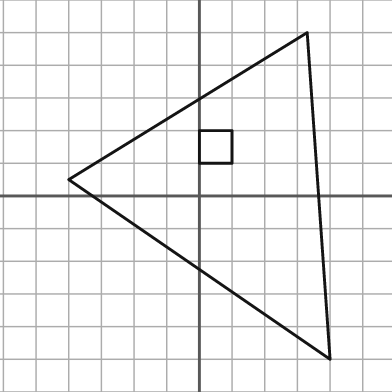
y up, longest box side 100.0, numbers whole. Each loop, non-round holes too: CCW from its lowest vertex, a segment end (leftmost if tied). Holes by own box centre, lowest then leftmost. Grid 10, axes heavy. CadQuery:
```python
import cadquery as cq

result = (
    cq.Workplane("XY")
    .moveTo(40.0, -50.0)
    .lineTo(33.0, 50.0)
    .lineTo(-40.0, 5.0)
    .close()
    .moveTo(0.0, 10.0)
    .lineTo(10.0, 10.0)
    .lineTo(10.0, 20.0)
    .lineTo(0.0, 20.0)
    .close()
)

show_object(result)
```